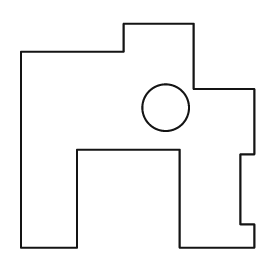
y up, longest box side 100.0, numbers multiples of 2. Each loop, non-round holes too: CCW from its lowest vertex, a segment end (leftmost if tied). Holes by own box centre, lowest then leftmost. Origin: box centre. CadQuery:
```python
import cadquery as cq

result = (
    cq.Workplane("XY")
    .moveTo(-50.0, -48.0)
    .lineTo(-26.0, -48.0)
    .lineTo(-26.0, -6.0)
    .lineTo(18.0, -6.0)
    .lineTo(18.0, -48.0)
    .lineTo(50.0, -48.0)
    .lineTo(50.0, -38.0)
    .lineTo(44.0, -38.0)
    .lineTo(44.0, -8.0)
    .lineTo(50.0, -8.0)
    .lineTo(50.0, 20.0)
    .lineTo(24.0, 20.0)
    .lineTo(24.0, 48.0)
    .lineTo(-6.0, 48.0)
    .lineTo(-6.0, 36.0)
    .lineTo(-50.0, 36.0)
    .close()
    .moveTo(12.0, 12.0)
    .circle(10.0)
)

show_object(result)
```